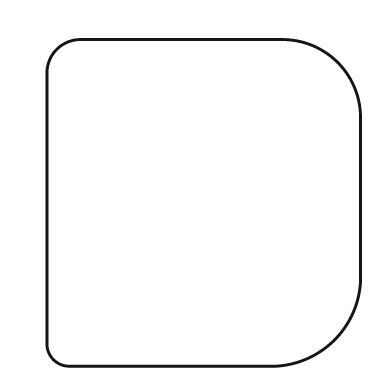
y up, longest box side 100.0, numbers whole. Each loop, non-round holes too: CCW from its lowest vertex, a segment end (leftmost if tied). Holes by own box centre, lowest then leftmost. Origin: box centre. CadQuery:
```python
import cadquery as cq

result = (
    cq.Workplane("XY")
    .moveTo(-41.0, -50.0)
    .lineTo(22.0, -50.0)
    .threePointArc((40.0, -42.0), (48.0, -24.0))
    .lineTo(48.0, 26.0)
    .threePointArc((41.0, 43.0), (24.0, 50.0))
    .lineTo(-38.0, 50.0)
    .threePointArc((-45.0, 47.0), (-48.0, 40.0))
    .lineTo(-48.0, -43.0)
    .threePointArc((-46.0, -48.0), (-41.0, -50.0))
    .close()
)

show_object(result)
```